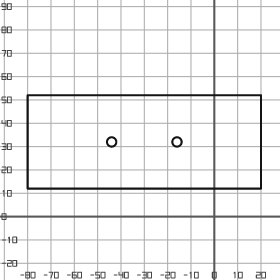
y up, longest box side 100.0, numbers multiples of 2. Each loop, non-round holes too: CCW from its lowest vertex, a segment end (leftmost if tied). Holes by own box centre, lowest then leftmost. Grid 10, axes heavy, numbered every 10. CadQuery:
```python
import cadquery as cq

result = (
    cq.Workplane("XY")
    .moveTo(-80.0, 12.0)
    .lineTo(20.0, 12.0)
    .lineTo(20.0, 52.0)
    .lineTo(-80.0, 52.0)
    .close()
    .moveTo(-44.0, 32.0)
    .circle(2.0)
    .moveTo(-16.0, 32.0)
    .circle(2.0)
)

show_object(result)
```